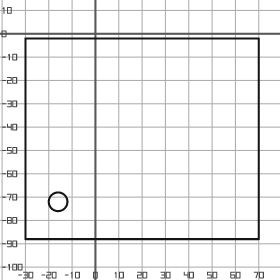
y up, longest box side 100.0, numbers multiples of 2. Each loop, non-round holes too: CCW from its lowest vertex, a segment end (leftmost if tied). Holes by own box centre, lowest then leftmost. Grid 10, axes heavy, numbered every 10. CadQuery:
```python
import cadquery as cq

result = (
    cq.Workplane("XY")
    .moveTo(-30.0, -88.0)
    .lineTo(70.0, -88.0)
    .lineTo(70.0, -2.0)
    .lineTo(-30.0, -2.0)
    .close()
    .moveTo(-16.0, -72.0)
    .circle(4.0)
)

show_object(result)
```